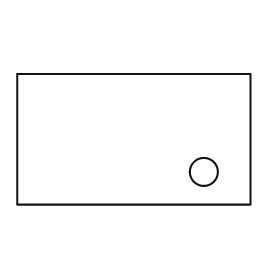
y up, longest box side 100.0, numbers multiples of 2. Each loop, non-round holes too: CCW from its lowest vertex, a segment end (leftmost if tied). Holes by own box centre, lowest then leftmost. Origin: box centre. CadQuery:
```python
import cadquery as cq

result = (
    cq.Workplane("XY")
    .moveTo(-50.0, -28.0)
    .lineTo(50.0, -28.0)
    .lineTo(50.0, 28.0)
    .lineTo(-50.0, 28.0)
    .close()
    .moveTo(30.0, -14.0)
    .circle(6.0)
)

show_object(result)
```